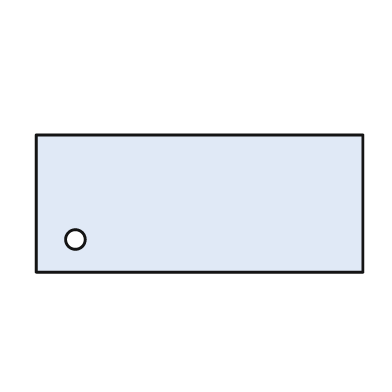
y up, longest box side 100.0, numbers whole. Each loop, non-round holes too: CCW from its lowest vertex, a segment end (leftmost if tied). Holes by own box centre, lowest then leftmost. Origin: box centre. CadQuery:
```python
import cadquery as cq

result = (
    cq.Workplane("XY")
    .moveTo(-50.0, -21.0)
    .lineTo(50.0, -21.0)
    .lineTo(50.0, 21.0)
    .lineTo(-50.0, 21.0)
    .close()
    .moveTo(-38.0, -11.0)
    .circle(3.0)
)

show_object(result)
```